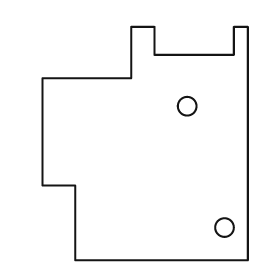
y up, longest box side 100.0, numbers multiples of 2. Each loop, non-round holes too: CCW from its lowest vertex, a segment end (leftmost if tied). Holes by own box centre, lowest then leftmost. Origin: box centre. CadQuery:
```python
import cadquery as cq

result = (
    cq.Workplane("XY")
    .moveTo(-30.0, -50.0)
    .lineTo(44.0, -50.0)
    .lineTo(44.0, 50.0)
    .lineTo(38.0, 50.0)
    .lineTo(38.0, 38.0)
    .lineTo(4.0, 38.0)
    .lineTo(4.0, 50.0)
    .lineTo(-6.0, 50.0)
    .lineTo(-6.0, 28.0)
    .lineTo(-44.0, 28.0)
    .lineTo(-44.0, -18.0)
    .lineTo(-30.0, -18.0)
    .close()
    .moveTo(34.0, -36.0)
    .circle(4.0)
    .moveTo(18.0, 16.0)
    .circle(4.0)
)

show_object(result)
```